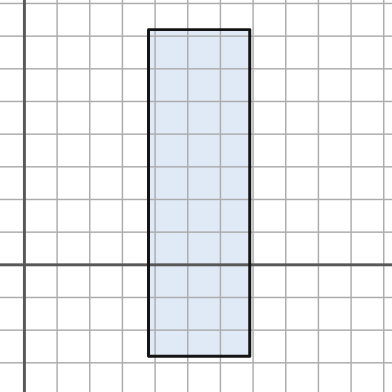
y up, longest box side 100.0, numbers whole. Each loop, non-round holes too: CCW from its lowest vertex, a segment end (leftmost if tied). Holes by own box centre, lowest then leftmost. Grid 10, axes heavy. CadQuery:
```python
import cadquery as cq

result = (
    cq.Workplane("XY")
    .moveTo(38.0, -28.0)
    .lineTo(69.0, -28.0)
    .lineTo(69.0, 72.0)
    .lineTo(38.0, 72.0)
    .close()
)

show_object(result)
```